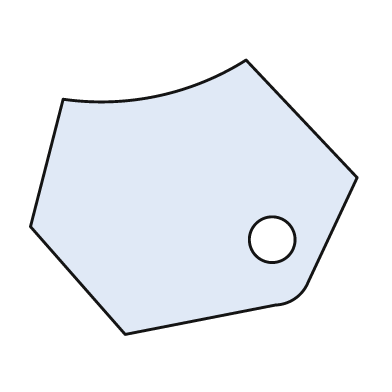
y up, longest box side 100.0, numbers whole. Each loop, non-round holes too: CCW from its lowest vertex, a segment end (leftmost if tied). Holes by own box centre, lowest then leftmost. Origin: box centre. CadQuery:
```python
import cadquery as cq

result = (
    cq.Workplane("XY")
    .moveTo(-21.0, -42.0)
    .lineTo(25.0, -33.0)
    .threePointArc((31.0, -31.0), (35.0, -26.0))
    .lineTo(50.0, 6.0)
    .lineTo(16.0, 42.0)
    .threePointArc((-11.0, 31.0), (-40.0, 30.0))
    .lineTo(-50.0, -9.0)
    .close()
    .moveTo(24.0, -13.0)
    .circle(7.0)
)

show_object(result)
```